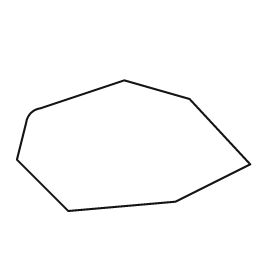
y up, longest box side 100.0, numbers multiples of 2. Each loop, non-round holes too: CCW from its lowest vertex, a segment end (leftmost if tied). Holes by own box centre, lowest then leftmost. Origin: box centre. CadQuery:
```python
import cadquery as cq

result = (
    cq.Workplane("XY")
    .moveTo(-28.0, -28.0)
    .lineTo(18.0, -24.0)
    .lineTo(50.0, -8.0)
    .lineTo(24.0, 20.0)
    .lineTo(-4.0, 28.0)
    .lineTo(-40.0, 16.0)
    .threePointArc((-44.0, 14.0), (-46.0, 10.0))
    .lineTo(-50.0, -6.0)
    .close()
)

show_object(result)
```